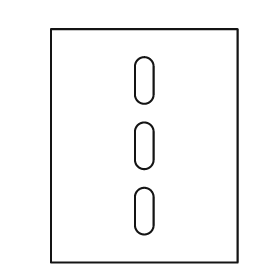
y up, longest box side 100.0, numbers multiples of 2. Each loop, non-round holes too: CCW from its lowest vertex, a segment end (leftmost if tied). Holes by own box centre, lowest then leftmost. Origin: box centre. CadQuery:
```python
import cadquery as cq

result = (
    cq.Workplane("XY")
    .moveTo(-40.0, -50.0)
    .lineTo(40.0, -50.0)
    .lineTo(40.0, 50.0)
    .lineTo(-40.0, 50.0)
    .close()
    .moveTo(-4.0, -34.0)
    .threePointArc((0.0, -38.0), (4.0, -34.0))
    .lineTo(4.0, -22.0)
    .threePointArc((0.0, -18.0), (-4.0, -22.0))
    .close()
    .moveTo(-4.0, -6.0)
    .threePointArc((0.0, -10.0), (4.0, -6.0))
    .lineTo(4.0, 6.0)
    .threePointArc((0.0, 10.0), (-4.0, 6.0))
    .close()
    .moveTo(-4.0, 22.0)
    .threePointArc((0.0, 18.0), (4.0, 22.0))
    .lineTo(4.0, 34.0)
    .threePointArc((0.0, 38.0), (-4.0, 34.0))
    .close()
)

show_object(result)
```